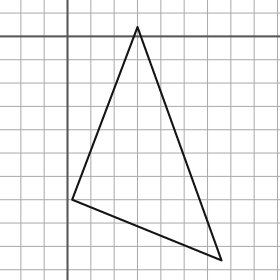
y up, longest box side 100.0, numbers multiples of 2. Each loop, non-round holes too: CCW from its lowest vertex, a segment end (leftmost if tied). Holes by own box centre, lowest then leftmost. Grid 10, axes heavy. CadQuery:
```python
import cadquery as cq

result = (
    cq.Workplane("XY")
    .moveTo(66.0, -96.0)
    .lineTo(30.0, 4.0)
    .lineTo(2.0, -70.0)
    .close()
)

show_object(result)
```